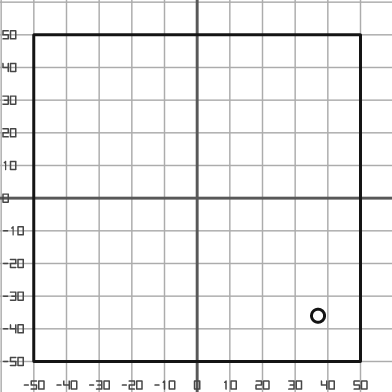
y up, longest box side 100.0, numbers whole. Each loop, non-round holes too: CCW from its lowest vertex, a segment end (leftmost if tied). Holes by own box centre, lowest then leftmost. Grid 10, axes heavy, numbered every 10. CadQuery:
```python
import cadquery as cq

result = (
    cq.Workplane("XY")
    .moveTo(-50.0, -50.0)
    .lineTo(50.0, -50.0)
    .lineTo(50.0, 50.0)
    .lineTo(-50.0, 50.0)
    .close()
    .moveTo(37.0, -36.0)
    .circle(2.0)
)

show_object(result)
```